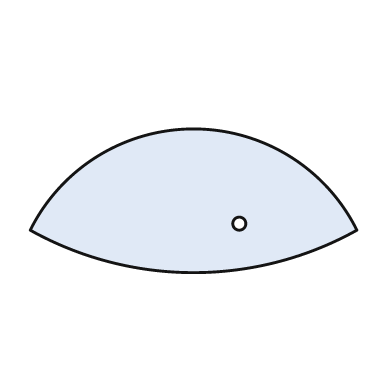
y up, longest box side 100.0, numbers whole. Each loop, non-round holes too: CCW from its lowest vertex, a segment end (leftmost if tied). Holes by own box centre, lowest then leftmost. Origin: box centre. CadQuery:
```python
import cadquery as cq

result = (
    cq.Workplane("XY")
    .moveTo(-50.0, -9.0)
    .threePointArc((0.0, -22.0), (50.0, -9.0))
    .threePointArc((0.0, 22.0), (-50.0, -9.0))
    .close()
    .moveTo(14.0, -7.0)
    .circle(2.0)
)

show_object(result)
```